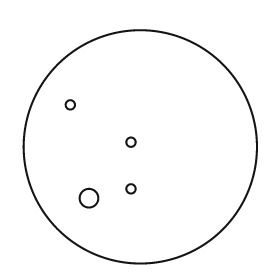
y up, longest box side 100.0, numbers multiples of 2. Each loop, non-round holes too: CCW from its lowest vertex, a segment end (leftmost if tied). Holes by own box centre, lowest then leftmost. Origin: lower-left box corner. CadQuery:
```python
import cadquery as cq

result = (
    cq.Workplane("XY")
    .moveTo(50.0, 50.0)
    .circle(50.0)
    .moveTo(28.0, 28.0)
    .circle(4.0)
    .moveTo(46.0, 32.0)
    .circle(2.0)
    .moveTo(46.0, 52.0)
    .circle(2.0)
    .moveTo(20.0, 68.0)
    .circle(2.0)
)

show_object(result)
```